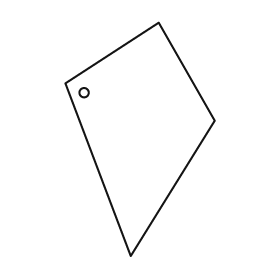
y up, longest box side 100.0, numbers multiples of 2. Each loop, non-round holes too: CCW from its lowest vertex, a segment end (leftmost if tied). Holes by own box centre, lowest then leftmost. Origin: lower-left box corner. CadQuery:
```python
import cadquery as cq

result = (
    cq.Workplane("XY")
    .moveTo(28.0, 0.0)
    .lineTo(64.0, 58.0)
    .lineTo(40.0, 100.0)
    .lineTo(0.0, 74.0)
    .close()
    .moveTo(8.0, 70.0)
    .circle(2.0)
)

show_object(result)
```